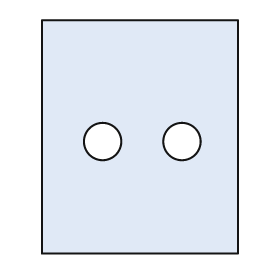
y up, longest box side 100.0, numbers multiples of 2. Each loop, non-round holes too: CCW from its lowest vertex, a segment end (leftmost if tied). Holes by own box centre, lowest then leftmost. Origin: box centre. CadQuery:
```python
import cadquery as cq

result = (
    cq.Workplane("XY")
    .moveTo(-42.0, -50.0)
    .lineTo(42.0, -50.0)
    .lineTo(42.0, 50.0)
    .lineTo(-42.0, 50.0)
    .close()
    .moveTo(-16.0, -2.0)
    .circle(8.0)
    .moveTo(18.0, -2.0)
    .circle(8.0)
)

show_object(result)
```